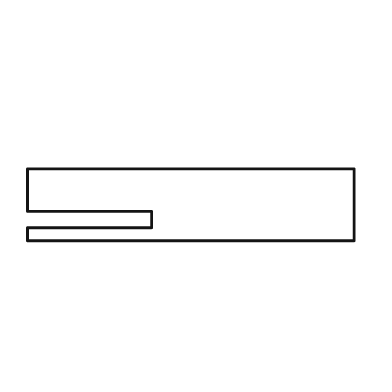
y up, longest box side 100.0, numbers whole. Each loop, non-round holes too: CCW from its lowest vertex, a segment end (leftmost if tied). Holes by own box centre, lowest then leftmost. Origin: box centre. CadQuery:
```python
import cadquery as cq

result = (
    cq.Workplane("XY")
    .moveTo(-50.0, -11.0)
    .lineTo(50.0, -11.0)
    .lineTo(50.0, 11.0)
    .lineTo(-50.0, 11.0)
    .lineTo(-50.0, -2.0)
    .lineTo(-12.0, -2.0)
    .lineTo(-12.0, -7.0)
    .lineTo(-50.0, -7.0)
    .close()
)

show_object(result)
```